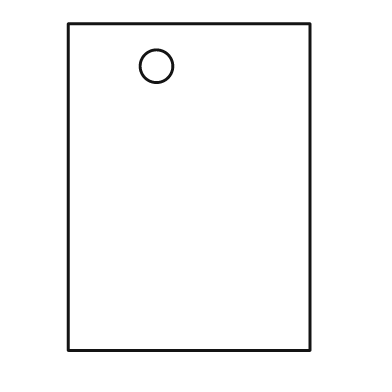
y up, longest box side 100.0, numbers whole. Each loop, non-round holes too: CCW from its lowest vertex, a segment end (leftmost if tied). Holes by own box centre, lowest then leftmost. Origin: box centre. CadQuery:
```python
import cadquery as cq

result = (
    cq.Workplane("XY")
    .moveTo(-37.0, -50.0)
    .lineTo(37.0, -50.0)
    .lineTo(37.0, 50.0)
    .lineTo(-37.0, 50.0)
    .close()
    .moveTo(-10.0, 37.0)
    .circle(5.0)
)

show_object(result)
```